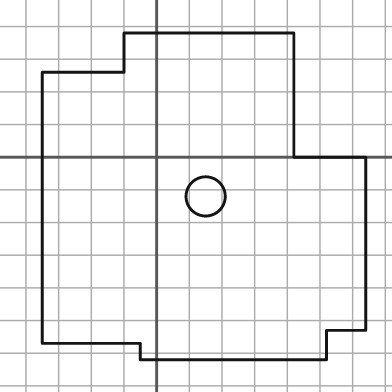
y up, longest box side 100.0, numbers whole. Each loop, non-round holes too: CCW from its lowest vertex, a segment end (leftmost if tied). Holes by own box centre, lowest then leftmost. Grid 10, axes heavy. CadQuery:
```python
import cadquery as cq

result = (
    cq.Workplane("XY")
    .moveTo(-5.0, -62.0)
    .lineTo(52.0, -62.0)
    .lineTo(52.0, -53.0)
    .lineTo(64.0, -53.0)
    .lineTo(64.0, 0.0)
    .lineTo(42.0, 0.0)
    .lineTo(42.0, 38.0)
    .lineTo(-10.0, 38.0)
    .lineTo(-10.0, 26.0)
    .lineTo(-35.0, 26.0)
    .lineTo(-35.0, -57.0)
    .lineTo(-5.0, -57.0)
    .close()
    .moveTo(15.0, -12.0)
    .circle(6.0)
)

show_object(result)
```